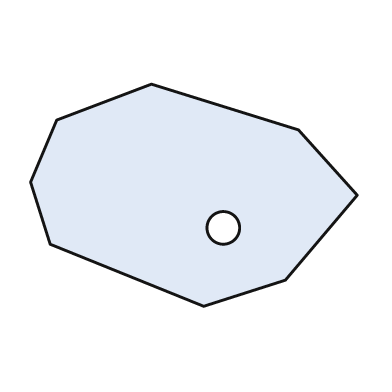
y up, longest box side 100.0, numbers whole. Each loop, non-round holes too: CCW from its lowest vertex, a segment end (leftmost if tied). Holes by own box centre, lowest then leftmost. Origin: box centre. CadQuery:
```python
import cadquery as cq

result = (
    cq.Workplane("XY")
    .moveTo(3.0, -34.0)
    .lineTo(28.0, -26.0)
    .lineTo(50.0, 0.0)
    .lineTo(32.0, 20.0)
    .lineTo(-13.0, 34.0)
    .lineTo(-42.0, 23.0)
    .lineTo(-50.0, 4.0)
    .lineTo(-44.0, -15.0)
    .close()
    .moveTo(9.0, -10.0)
    .circle(5.0)
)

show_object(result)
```